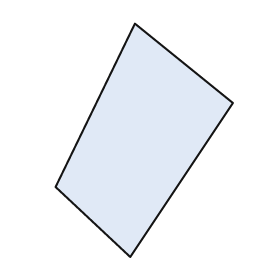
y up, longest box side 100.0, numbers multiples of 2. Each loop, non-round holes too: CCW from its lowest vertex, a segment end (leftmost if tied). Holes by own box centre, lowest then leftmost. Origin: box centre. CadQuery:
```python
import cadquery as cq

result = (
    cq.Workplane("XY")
    .moveTo(-6.0, -50.0)
    .lineTo(38.0, 16.0)
    .lineTo(-4.0, 50.0)
    .lineTo(-38.0, -20.0)
    .close()
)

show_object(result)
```